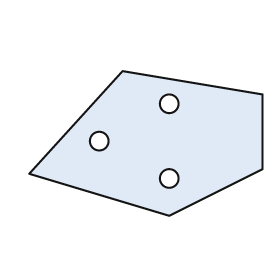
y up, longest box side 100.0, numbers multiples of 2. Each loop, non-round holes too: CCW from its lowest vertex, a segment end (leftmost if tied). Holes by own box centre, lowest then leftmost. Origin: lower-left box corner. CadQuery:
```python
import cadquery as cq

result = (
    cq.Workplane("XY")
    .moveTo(60.0, 0.0)
    .lineTo(100.0, 20.0)
    .lineTo(100.0, 52.0)
    .lineTo(40.0, 62.0)
    .lineTo(0.0, 18.0)
    .close()
    .moveTo(60.0, 16.0)
    .circle(4.0)
    .moveTo(30.0, 32.0)
    .circle(4.0)
    .moveTo(60.0, 48.0)
    .circle(4.0)
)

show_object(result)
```